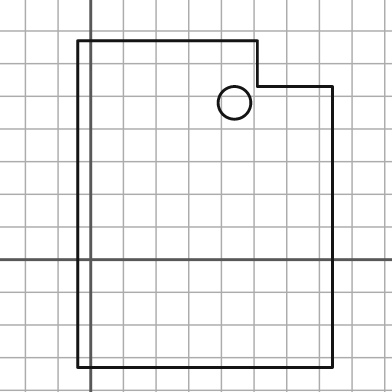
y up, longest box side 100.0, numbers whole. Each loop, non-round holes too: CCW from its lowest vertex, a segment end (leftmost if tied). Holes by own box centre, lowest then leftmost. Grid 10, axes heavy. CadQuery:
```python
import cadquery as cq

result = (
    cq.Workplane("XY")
    .moveTo(-4.0, -33.0)
    .lineTo(74.0, -33.0)
    .lineTo(74.0, 53.0)
    .lineTo(51.0, 53.0)
    .lineTo(51.0, 67.0)
    .lineTo(-4.0, 67.0)
    .close()
    .moveTo(44.0, 48.0)
    .circle(5.0)
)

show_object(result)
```